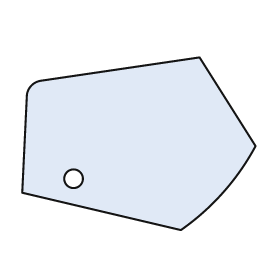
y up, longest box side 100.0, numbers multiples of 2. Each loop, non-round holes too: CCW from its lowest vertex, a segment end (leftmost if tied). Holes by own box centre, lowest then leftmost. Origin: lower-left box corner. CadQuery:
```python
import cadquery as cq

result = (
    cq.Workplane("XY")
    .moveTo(68.0, 0.0)
    .threePointArc((86.0, 16.0), (100.0, 36.0))
    .lineTo(76.0, 74.0)
    .lineTo(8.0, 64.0)
    .threePointArc((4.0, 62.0), (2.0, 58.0))
    .lineTo(0.0, 16.0)
    .close()
    .moveTo(22.0, 22.0)
    .circle(4.0)
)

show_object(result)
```